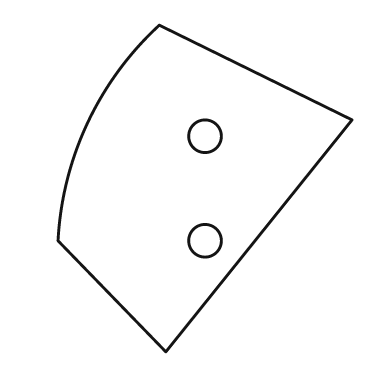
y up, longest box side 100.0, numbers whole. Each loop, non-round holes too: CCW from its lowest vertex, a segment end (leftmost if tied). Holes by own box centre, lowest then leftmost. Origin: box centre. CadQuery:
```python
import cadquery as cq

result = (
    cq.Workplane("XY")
    .moveTo(-12.0, -50.0)
    .lineTo(45.0, 21.0)
    .lineTo(-14.0, 50.0)
    .threePointArc((-36.0, 20.0), (-45.0, -16.0))
    .close()
    .moveTo(0.0, -16.0)
    .circle(5.0)
    .moveTo(0.0, 16.0)
    .circle(5.0)
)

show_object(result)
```